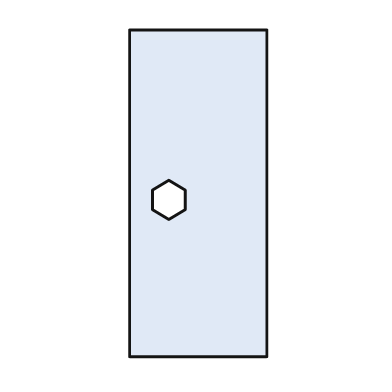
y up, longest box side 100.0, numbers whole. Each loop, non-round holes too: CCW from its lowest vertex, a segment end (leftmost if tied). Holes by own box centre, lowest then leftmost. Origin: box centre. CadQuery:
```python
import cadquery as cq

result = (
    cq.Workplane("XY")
    .moveTo(-21.0, -50.0)
    .lineTo(21.0, -50.0)
    .lineTo(21.0, 50.0)
    .lineTo(-21.0, 50.0)
    .close()
    .moveTo(-9.0, -8.0)
    .lineTo(-4.0, -5.0)
    .lineTo(-4.0, 1.0)
    .lineTo(-9.0, 4.0)
    .lineTo(-14.0, 1.0)
    .lineTo(-14.0, -5.0)
    .close()
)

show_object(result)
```